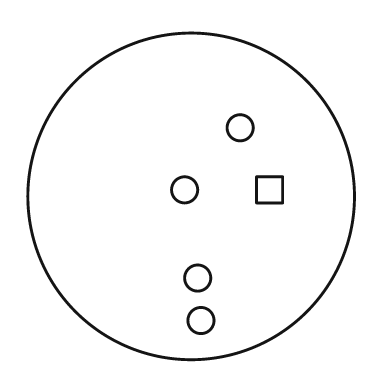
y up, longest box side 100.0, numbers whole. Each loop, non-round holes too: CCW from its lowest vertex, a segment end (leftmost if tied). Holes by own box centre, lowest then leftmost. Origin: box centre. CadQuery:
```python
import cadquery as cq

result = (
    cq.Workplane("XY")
    .moveTo(0.0, 0.0)
    .circle(50.0)
    .moveTo(3.0, -38.0)
    .circle(4.0)
    .moveTo(2.0, -25.0)
    .circle(4.0)
    .moveTo(-2.0, 2.0)
    .circle(4.0)
    .moveTo(20.0, -2.0)
    .lineTo(28.0, -2.0)
    .lineTo(28.0, 6.0)
    .lineTo(20.0, 6.0)
    .close()
    .moveTo(15.0, 21.0)
    .circle(4.0)
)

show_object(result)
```